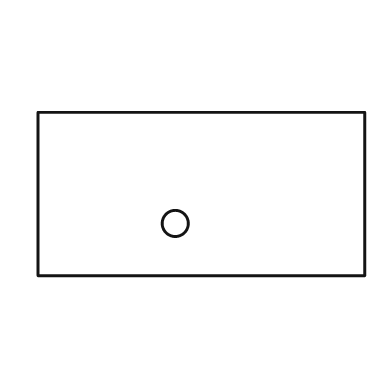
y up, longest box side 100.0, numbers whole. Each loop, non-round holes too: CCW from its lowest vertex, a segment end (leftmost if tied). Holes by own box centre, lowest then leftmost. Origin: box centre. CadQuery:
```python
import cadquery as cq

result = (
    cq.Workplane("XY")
    .moveTo(-50.0, -25.0)
    .lineTo(50.0, -25.0)
    .lineTo(50.0, 25.0)
    .lineTo(-50.0, 25.0)
    .close()
    .moveTo(-8.0, -9.0)
    .circle(4.0)
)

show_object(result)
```